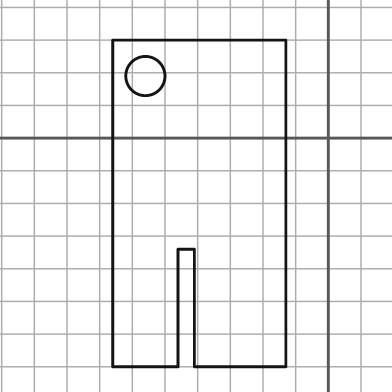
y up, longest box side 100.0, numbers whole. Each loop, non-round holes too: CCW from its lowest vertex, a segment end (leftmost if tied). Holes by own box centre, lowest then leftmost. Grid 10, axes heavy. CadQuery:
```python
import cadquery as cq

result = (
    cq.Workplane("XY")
    .moveTo(-66.0, -70.0)
    .lineTo(-46.0, -70.0)
    .lineTo(-46.0, -34.0)
    .lineTo(-41.0, -34.0)
    .lineTo(-41.0, -70.0)
    .lineTo(-13.0, -70.0)
    .lineTo(-13.0, 30.0)
    .lineTo(-66.0, 30.0)
    .close()
    .moveTo(-56.0, 19.0)
    .circle(6.0)
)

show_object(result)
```